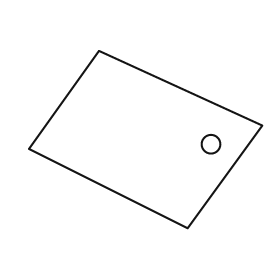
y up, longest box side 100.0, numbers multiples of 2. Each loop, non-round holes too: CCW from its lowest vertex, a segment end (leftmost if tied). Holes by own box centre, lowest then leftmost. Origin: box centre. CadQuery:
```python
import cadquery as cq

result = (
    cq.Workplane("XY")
    .moveTo(18.0, -38.0)
    .lineTo(50.0, 6.0)
    .lineTo(-20.0, 38.0)
    .lineTo(-50.0, -4.0)
    .close()
    .moveTo(28.0, -2.0)
    .circle(4.0)
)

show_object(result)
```